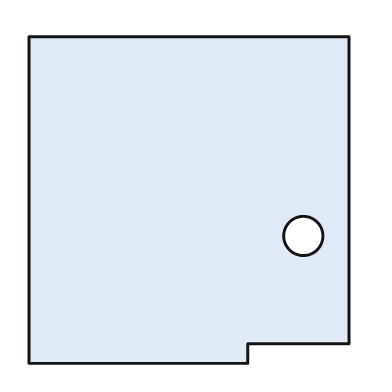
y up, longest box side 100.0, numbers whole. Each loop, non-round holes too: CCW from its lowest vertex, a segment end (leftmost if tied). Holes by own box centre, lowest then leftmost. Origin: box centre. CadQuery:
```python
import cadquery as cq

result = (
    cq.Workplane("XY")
    .moveTo(-49.0, -50.0)
    .lineTo(18.0, -50.0)
    .lineTo(18.0, -44.0)
    .lineTo(49.0, -44.0)
    .lineTo(49.0, 50.0)
    .lineTo(-49.0, 50.0)
    .close()
    .moveTo(35.0, -11.0)
    .circle(6.0)
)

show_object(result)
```